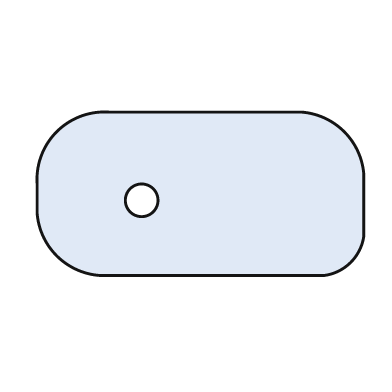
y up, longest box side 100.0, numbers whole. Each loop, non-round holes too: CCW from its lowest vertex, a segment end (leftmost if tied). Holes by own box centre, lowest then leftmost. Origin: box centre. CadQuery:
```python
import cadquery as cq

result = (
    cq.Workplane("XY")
    .moveTo(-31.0, -25.0)
    .lineTo(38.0, -25.0)
    .threePointArc((46.0, -21.0), (50.0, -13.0))
    .lineTo(50.0, 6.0)
    .threePointArc((44.0, 19.0), (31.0, 25.0))
    .lineTo(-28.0, 25.0)
    .threePointArc((-44.0, 19.0), (-50.0, 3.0))
    .lineTo(-50.0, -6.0)
    .threePointArc((-44.0, -19.0), (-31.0, -25.0))
    .close()
    .moveTo(-18.0, -2.0)
    .circle(5.0)
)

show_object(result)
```